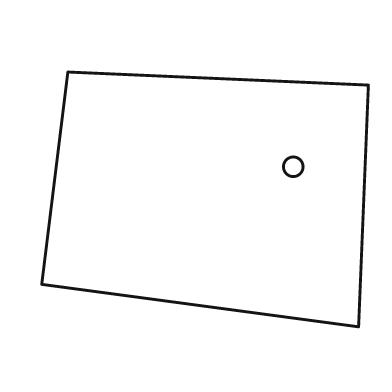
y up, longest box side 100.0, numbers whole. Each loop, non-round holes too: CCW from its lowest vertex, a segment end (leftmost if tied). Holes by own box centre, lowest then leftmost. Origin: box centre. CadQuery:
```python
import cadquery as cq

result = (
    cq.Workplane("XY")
    .moveTo(47.0, -39.0)
    .lineTo(50.0, 35.0)
    .lineTo(-42.0, 39.0)
    .lineTo(-50.0, -26.0)
    .close()
    .moveTo(27.0, 10.0)
    .circle(3.0)
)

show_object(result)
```